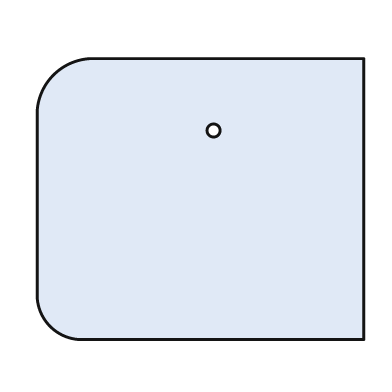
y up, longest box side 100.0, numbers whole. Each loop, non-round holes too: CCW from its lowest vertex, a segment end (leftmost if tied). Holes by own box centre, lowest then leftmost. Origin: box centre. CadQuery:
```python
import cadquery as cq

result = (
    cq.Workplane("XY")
    .moveTo(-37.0, -43.0)
    .lineTo(50.0, -43.0)
    .lineTo(50.0, 43.0)
    .lineTo(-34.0, 43.0)
    .threePointArc((-45.0, 38.0), (-50.0, 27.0))
    .lineTo(-50.0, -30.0)
    .threePointArc((-46.0, -39.0), (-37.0, -43.0))
    .close()
    .moveTo(4.0, 21.0)
    .circle(2.0)
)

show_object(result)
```